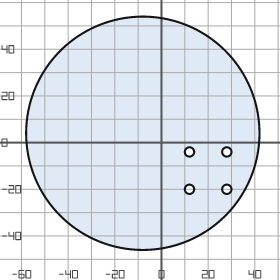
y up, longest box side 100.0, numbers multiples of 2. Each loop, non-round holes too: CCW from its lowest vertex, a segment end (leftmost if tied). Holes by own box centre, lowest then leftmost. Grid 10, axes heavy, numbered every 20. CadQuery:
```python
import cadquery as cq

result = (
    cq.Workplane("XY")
    .moveTo(-8.0, 4.0)
    .circle(50.0)
    .moveTo(12.0, -20.0)
    .circle(2.0)
    .moveTo(28.0, -20.0)
    .circle(2.0)
    .moveTo(12.0, -4.0)
    .circle(2.0)
    .moveTo(28.0, -4.0)
    .circle(2.0)
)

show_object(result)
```